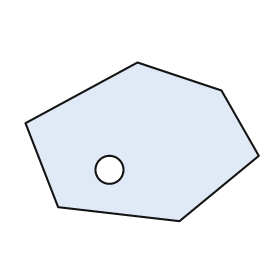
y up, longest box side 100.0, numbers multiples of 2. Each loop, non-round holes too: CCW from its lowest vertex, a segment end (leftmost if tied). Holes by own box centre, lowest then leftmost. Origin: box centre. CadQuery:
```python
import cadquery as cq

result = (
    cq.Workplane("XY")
    .moveTo(16.0, -34.0)
    .lineTo(50.0, -6.0)
    .lineTo(34.0, 22.0)
    .lineTo(-2.0, 34.0)
    .lineTo(-50.0, 8.0)
    .lineTo(-36.0, -28.0)
    .close()
    .moveTo(-14.0, -12.0)
    .circle(6.0)
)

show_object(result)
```